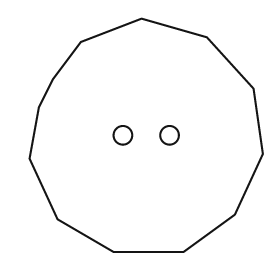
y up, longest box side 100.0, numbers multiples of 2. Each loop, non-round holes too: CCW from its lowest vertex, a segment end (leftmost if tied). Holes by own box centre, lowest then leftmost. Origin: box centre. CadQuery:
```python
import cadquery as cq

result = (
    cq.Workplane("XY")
    .moveTo(-14.0, -50.0)
    .lineTo(16.0, -50.0)
    .lineTo(38.0, -34.0)
    .lineTo(50.0, -8.0)
    .lineTo(46.0, 20.0)
    .lineTo(26.0, 42.0)
    .lineTo(-2.0, 50.0)
    .lineTo(-28.0, 40.0)
    .lineTo(-40.0, 24.0)
    .lineTo(-46.0, 12.0)
    .lineTo(-50.0, -10.0)
    .lineTo(-38.0, -36.0)
    .close()
    .moveTo(-10.0, 0.0)
    .circle(4.0)
    .moveTo(10.0, 0.0)
    .circle(4.0)
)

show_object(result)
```